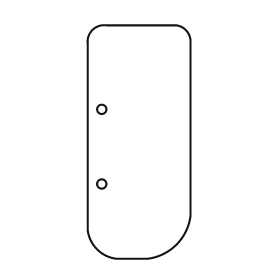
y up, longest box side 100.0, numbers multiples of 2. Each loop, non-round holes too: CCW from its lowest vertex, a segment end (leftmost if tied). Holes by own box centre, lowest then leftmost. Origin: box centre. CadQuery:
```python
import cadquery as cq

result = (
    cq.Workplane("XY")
    .moveTo(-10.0, -50.0)
    .lineTo(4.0, -50.0)
    .threePointArc((16.0, -44.0), (22.0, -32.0))
    .lineTo(22.0, 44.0)
    .threePointArc((20.0, 48.0), (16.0, 50.0))
    .lineTo(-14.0, 50.0)
    .threePointArc((-20.0, 48.0), (-22.0, 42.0))
    .lineTo(-22.0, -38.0)
    .threePointArc((-18.0, -46.0), (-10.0, -50.0))
    .close()
    .moveTo(-16.0, -18.0)
    .circle(2.0)
    .moveTo(-16.0, 14.0)
    .circle(2.0)
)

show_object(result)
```